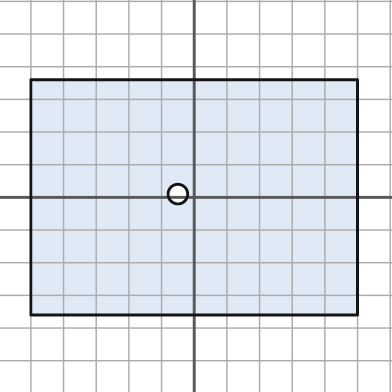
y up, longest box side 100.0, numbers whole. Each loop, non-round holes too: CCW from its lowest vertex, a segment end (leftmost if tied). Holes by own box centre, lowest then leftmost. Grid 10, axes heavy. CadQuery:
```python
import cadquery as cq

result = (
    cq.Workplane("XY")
    .moveTo(-50.0, -36.0)
    .lineTo(50.0, -36.0)
    .lineTo(50.0, 36.0)
    .lineTo(-50.0, 36.0)
    .close()
    .moveTo(-5.0, 1.0)
    .circle(3.0)
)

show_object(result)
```